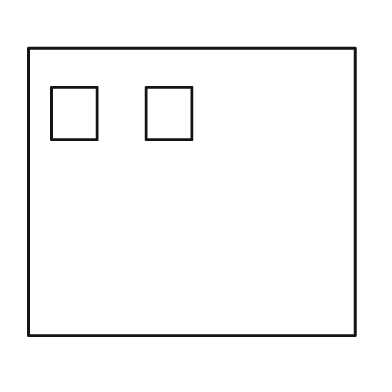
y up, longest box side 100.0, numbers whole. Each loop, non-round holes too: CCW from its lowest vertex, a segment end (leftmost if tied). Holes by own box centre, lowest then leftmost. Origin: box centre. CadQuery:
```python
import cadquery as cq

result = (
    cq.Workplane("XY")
    .moveTo(-50.0, -44.0)
    .lineTo(50.0, -44.0)
    .lineTo(50.0, 44.0)
    .lineTo(-50.0, 44.0)
    .close()
    .moveTo(-43.0, 16.0)
    .lineTo(-29.0, 16.0)
    .lineTo(-29.0, 32.0)
    .lineTo(-43.0, 32.0)
    .close()
    .moveTo(-14.0, 16.0)
    .lineTo(0.0, 16.0)
    .lineTo(0.0, 32.0)
    .lineTo(-14.0, 32.0)
    .close()
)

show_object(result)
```